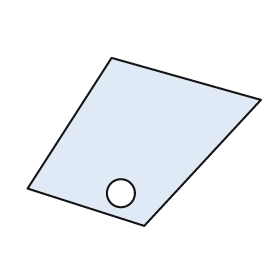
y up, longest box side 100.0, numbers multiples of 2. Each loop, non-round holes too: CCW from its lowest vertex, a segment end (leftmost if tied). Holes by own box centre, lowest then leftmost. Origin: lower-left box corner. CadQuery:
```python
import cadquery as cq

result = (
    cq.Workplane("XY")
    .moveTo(50.0, 0.0)
    .lineTo(100.0, 54.0)
    .lineTo(36.0, 72.0)
    .lineTo(0.0, 16.0)
    .close()
    .moveTo(40.0, 14.0)
    .circle(6.0)
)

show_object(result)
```